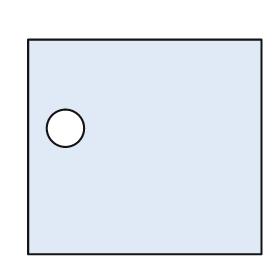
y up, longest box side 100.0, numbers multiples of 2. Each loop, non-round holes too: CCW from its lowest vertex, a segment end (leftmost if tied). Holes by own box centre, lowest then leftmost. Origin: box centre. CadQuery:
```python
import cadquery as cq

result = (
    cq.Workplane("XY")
    .moveTo(-50.0, -46.0)
    .lineTo(50.0, -46.0)
    .lineTo(50.0, 46.0)
    .lineTo(-50.0, 46.0)
    .close()
    .moveTo(-34.0, 8.0)
    .circle(8.0)
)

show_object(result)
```